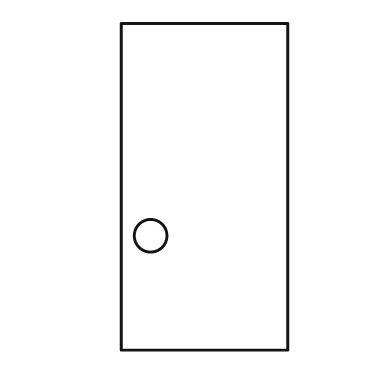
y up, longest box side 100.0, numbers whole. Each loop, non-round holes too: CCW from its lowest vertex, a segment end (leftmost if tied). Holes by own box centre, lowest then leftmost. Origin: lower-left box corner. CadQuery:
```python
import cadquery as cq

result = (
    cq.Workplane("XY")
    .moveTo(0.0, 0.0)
    .lineTo(51.0, 0.0)
    .lineTo(51.0, 100.0)
    .lineTo(0.0, 100.0)
    .close()
    .moveTo(9.0, 35.0)
    .circle(5.0)
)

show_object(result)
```